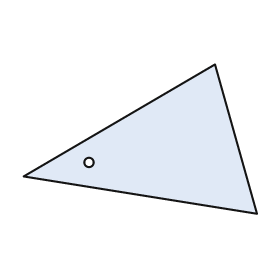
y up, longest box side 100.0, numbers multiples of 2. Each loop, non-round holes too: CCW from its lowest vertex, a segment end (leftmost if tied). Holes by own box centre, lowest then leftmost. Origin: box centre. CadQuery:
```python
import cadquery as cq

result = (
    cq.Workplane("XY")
    .moveTo(50.0, -32.0)
    .lineTo(32.0, 32.0)
    .lineTo(-50.0, -16.0)
    .close()
    .moveTo(-22.0, -10.0)
    .circle(2.0)
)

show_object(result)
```